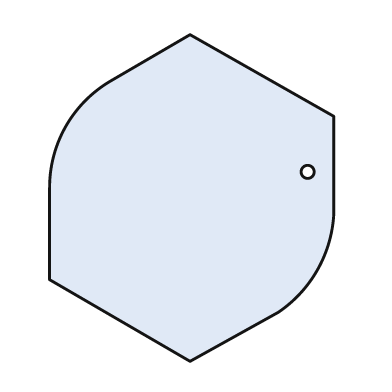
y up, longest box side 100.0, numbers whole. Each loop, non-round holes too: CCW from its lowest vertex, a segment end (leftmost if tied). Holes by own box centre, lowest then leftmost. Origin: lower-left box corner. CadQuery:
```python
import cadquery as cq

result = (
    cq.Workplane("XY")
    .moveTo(43.0, 0.0)
    .lineTo(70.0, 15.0)
    .threePointArc((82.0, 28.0), (87.0, 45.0))
    .lineTo(87.0, 75.0)
    .lineTo(43.0, 100.0)
    .lineTo(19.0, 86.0)
    .threePointArc((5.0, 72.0), (0.0, 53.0))
    .lineTo(0.0, 25.0)
    .close()
    .moveTo(79.0, 58.0)
    .circle(2.0)
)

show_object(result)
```